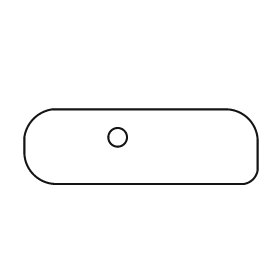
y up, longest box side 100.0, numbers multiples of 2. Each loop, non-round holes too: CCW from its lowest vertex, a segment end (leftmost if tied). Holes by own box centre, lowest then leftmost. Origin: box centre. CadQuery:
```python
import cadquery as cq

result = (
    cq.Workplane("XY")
    .moveTo(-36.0, -16.0)
    .lineTo(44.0, -16.0)
    .threePointArc((48.0, -14.0), (50.0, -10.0))
    .lineTo(50.0, 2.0)
    .threePointArc((46.0, 12.0), (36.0, 16.0))
    .lineTo(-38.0, 16.0)
    .threePointArc((-46.0, 12.0), (-50.0, 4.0))
    .lineTo(-50.0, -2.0)
    .threePointArc((-46.0, -12.0), (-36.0, -16.0))
    .close()
    .moveTo(-10.0, 4.0)
    .circle(4.0)
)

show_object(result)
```